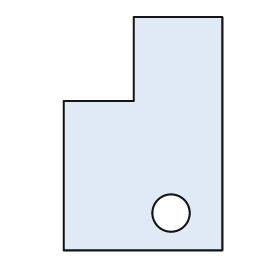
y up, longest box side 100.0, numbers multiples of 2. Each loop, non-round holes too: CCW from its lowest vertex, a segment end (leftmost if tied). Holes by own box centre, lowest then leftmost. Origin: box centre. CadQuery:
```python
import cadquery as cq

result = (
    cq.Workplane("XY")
    .moveTo(-34.0, -50.0)
    .lineTo(34.0, -50.0)
    .lineTo(34.0, 50.0)
    .lineTo(-4.0, 50.0)
    .lineTo(-4.0, 14.0)
    .lineTo(-34.0, 14.0)
    .close()
    .moveTo(12.0, -34.0)
    .circle(8.0)
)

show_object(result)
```